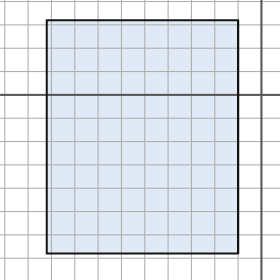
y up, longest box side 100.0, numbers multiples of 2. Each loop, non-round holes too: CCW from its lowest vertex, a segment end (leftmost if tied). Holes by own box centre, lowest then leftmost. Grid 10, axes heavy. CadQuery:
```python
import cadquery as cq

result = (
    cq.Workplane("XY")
    .moveTo(-92.0, -68.0)
    .lineTo(-10.0, -68.0)
    .lineTo(-10.0, 32.0)
    .lineTo(-92.0, 32.0)
    .close()
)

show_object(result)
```